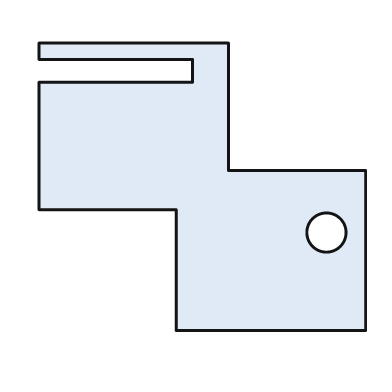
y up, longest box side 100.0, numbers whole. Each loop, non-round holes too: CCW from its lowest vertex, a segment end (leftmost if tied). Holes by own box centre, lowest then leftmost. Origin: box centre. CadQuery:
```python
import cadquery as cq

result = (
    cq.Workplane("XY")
    .moveTo(-8.0, -44.0)
    .lineTo(50.0, -44.0)
    .lineTo(50.0, 5.0)
    .lineTo(8.0, 5.0)
    .lineTo(8.0, 44.0)
    .lineTo(-50.0, 44.0)
    .lineTo(-50.0, 39.0)
    .lineTo(-3.0, 39.0)
    .lineTo(-3.0, 32.0)
    .lineTo(-50.0, 32.0)
    .lineTo(-50.0, -7.0)
    .lineTo(-8.0, -7.0)
    .close()
    .moveTo(38.0, -14.0)
    .circle(6.0)
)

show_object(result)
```